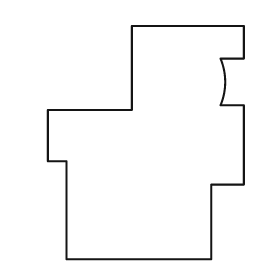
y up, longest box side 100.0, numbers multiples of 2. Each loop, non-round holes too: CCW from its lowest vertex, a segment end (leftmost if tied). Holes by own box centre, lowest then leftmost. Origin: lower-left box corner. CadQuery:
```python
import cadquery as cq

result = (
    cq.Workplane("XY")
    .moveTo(8.0, 0.0)
    .lineTo(70.0, 0.0)
    .lineTo(70.0, 32.0)
    .lineTo(84.0, 32.0)
    .lineTo(84.0, 66.0)
    .lineTo(74.0, 66.0)
    .threePointArc((76.0, 76.0), (74.0, 86.0))
    .lineTo(84.0, 86.0)
    .lineTo(84.0, 100.0)
    .lineTo(36.0, 100.0)
    .lineTo(36.0, 64.0)
    .lineTo(0.0, 64.0)
    .lineTo(0.0, 42.0)
    .lineTo(8.0, 42.0)
    .close()
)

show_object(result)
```